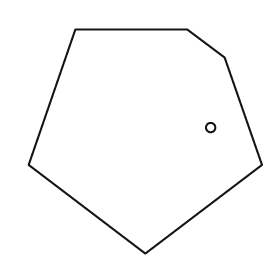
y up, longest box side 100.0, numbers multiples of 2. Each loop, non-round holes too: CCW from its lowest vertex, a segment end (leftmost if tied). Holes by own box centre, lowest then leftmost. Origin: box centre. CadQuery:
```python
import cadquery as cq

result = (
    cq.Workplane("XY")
    .moveTo(0.0, -48.0)
    .lineTo(50.0, -10.0)
    .lineTo(34.0, 36.0)
    .lineTo(18.0, 48.0)
    .lineTo(-30.0, 48.0)
    .lineTo(-50.0, -10.0)
    .close()
    .moveTo(28.0, 6.0)
    .circle(2.0)
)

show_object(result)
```